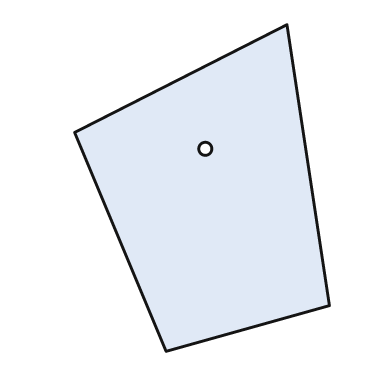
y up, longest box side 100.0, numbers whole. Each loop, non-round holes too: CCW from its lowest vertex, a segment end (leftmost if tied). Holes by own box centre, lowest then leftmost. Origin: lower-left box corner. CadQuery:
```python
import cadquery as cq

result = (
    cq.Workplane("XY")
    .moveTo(28.0, 0.0)
    .lineTo(78.0, 14.0)
    .lineTo(65.0, 100.0)
    .lineTo(0.0, 67.0)
    .close()
    .moveTo(40.0, 62.0)
    .circle(2.0)
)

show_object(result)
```